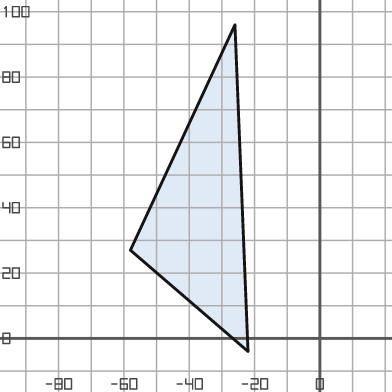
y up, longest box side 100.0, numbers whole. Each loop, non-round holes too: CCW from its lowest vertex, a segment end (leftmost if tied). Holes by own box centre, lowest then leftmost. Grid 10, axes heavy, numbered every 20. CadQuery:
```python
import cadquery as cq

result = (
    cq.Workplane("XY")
    .moveTo(-22.0, -4.0)
    .lineTo(-26.0, 96.0)
    .lineTo(-58.0, 27.0)
    .close()
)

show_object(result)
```